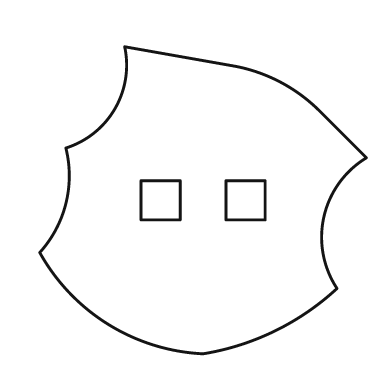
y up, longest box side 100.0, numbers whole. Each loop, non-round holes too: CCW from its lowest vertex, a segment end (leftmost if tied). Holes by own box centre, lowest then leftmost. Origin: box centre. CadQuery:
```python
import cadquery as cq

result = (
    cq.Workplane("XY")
    .moveTo(0.0, -47.0)
    .threePointArc((22.0, -40.0), (41.0, -27.0))
    .threePointArc((37.0, -5.0), (50.0, 13.0))
    .lineTo(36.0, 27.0)
    .threePointArc((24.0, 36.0), (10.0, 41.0))
    .lineTo(-24.0, 47.0)
    .threePointArc((-27.0, 28.0), (-42.0, 16.0))
    .threePointArc((-42.0, -1.0), (-50.0, -16.0))
    .threePointArc((-29.0, -38.0), (0.0, -47.0))
    .close()
    .moveTo(-19.0, -6.0)
    .lineTo(-7.0, -6.0)
    .lineTo(-7.0, 6.0)
    .lineTo(-19.0, 6.0)
    .close()
    .moveTo(7.0, -6.0)
    .lineTo(19.0, -6.0)
    .lineTo(19.0, 6.0)
    .lineTo(7.0, 6.0)
    .close()
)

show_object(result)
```